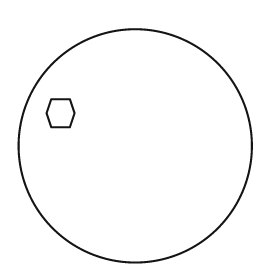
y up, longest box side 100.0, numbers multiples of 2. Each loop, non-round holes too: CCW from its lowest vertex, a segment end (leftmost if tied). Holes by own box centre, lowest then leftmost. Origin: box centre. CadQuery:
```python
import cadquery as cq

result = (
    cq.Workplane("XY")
    .moveTo(0.0, 0.0)
    .circle(50.0)
    .moveTo(-36.0, 8.0)
    .lineTo(-28.0, 8.0)
    .lineTo(-26.0, 14.0)
    .lineTo(-28.0, 20.0)
    .lineTo(-36.0, 20.0)
    .lineTo(-38.0, 14.0)
    .close()
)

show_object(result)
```